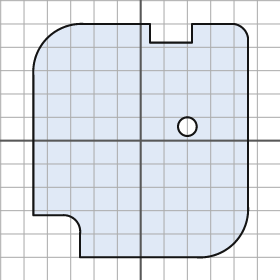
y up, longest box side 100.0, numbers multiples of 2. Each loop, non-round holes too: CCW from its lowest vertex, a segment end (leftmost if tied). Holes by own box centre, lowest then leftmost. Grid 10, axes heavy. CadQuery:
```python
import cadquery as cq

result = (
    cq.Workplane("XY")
    .moveTo(-26.0, -50.0)
    .lineTo(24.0, -50.0)
    .threePointArc((40.0, -44.0), (46.0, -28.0))
    .lineTo(46.0, 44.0)
    .threePointArc((44.0, 48.0), (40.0, 50.0))
    .lineTo(22.0, 50.0)
    .lineTo(22.0, 42.0)
    .lineTo(4.0, 42.0)
    .lineTo(4.0, 50.0)
    .lineTo(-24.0, 50.0)
    .threePointArc((-40.0, 44.0), (-46.0, 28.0))
    .lineTo(-46.0, -32.0)
    .lineTo(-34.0, -32.0)
    .threePointArc((-28.0, -34.0), (-26.0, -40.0))
    .close()
    .moveTo(20.0, 6.0)
    .circle(4.0)
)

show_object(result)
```